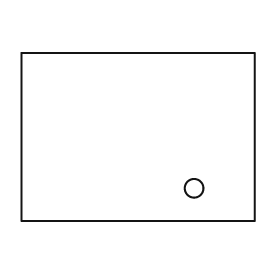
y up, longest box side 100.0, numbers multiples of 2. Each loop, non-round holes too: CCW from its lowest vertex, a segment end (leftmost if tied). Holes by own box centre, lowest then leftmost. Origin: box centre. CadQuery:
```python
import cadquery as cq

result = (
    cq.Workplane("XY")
    .moveTo(-50.0, -36.0)
    .lineTo(50.0, -36.0)
    .lineTo(50.0, 36.0)
    .lineTo(-50.0, 36.0)
    .close()
    .moveTo(24.0, -22.0)
    .circle(4.0)
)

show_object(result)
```